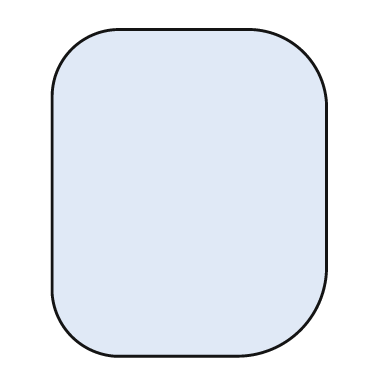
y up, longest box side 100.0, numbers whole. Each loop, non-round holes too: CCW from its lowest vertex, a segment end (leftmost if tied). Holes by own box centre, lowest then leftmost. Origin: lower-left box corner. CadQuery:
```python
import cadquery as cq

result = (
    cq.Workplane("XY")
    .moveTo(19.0, 0.0)
    .lineTo(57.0, 0.0)
    .threePointArc((76.0, 8.0), (84.0, 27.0))
    .lineTo(84.0, 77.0)
    .threePointArc((77.0, 93.0), (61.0, 100.0))
    .lineTo(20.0, 100.0)
    .threePointArc((6.0, 94.0), (0.0, 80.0))
    .lineTo(0.0, 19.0)
    .threePointArc((6.0, 6.0), (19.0, 0.0))
    .close()
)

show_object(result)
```